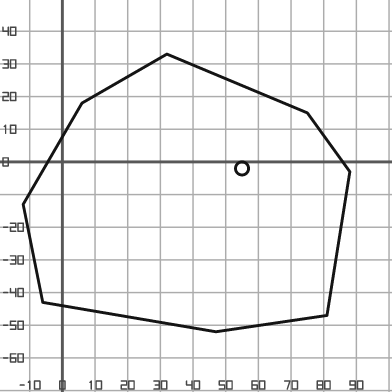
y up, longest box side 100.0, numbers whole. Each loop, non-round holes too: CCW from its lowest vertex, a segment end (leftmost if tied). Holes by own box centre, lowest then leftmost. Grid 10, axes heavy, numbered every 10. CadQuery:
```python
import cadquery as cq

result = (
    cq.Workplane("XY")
    .moveTo(47.0, -52.0)
    .lineTo(81.0, -47.0)
    .lineTo(88.0, -3.0)
    .lineTo(75.0, 15.0)
    .lineTo(32.0, 33.0)
    .lineTo(6.0, 18.0)
    .lineTo(-12.0, -13.0)
    .lineTo(-6.0, -43.0)
    .close()
    .moveTo(55.0, -2.0)
    .circle(2.0)
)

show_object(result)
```